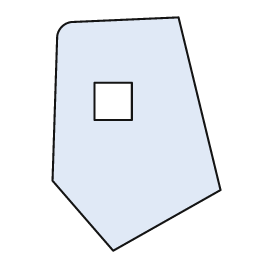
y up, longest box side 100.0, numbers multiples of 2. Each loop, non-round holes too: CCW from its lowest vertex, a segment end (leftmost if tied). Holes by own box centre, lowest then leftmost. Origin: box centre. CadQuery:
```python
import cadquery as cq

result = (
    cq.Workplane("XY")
    .moveTo(-10.0, -50.0)
    .lineTo(36.0, -24.0)
    .lineTo(18.0, 50.0)
    .lineTo(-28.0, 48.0)
    .threePointArc((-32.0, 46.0), (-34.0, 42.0))
    .lineTo(-36.0, -20.0)
    .close()
    .moveTo(-18.0, 6.0)
    .lineTo(-2.0, 6.0)
    .lineTo(-2.0, 22.0)
    .lineTo(-18.0, 22.0)
    .close()
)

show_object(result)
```